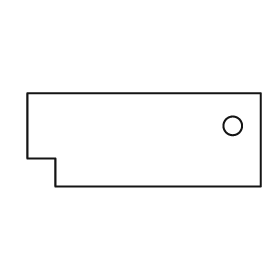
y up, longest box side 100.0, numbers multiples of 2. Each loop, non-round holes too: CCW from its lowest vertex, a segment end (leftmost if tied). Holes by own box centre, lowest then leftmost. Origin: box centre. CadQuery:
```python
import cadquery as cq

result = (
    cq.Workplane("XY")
    .moveTo(-38.0, -20.0)
    .lineTo(50.0, -20.0)
    .lineTo(50.0, 20.0)
    .lineTo(-50.0, 20.0)
    .lineTo(-50.0, -8.0)
    .lineTo(-38.0, -8.0)
    .close()
    .moveTo(38.0, 6.0)
    .circle(4.0)
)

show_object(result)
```